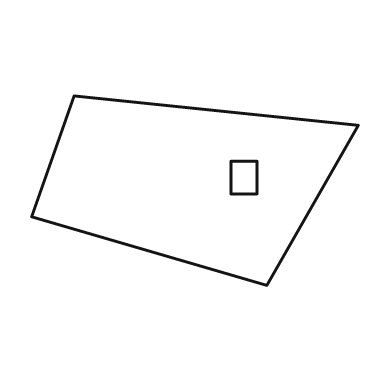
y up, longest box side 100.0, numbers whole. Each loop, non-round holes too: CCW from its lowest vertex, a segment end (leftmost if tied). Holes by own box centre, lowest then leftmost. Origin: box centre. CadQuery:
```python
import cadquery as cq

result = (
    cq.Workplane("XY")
    .moveTo(22.0, -29.0)
    .lineTo(50.0, 20.0)
    .lineTo(-37.0, 29.0)
    .lineTo(-50.0, -8.0)
    .close()
    .moveTo(11.0, -1.0)
    .lineTo(19.0, -1.0)
    .lineTo(19.0, 9.0)
    .lineTo(11.0, 9.0)
    .close()
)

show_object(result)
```